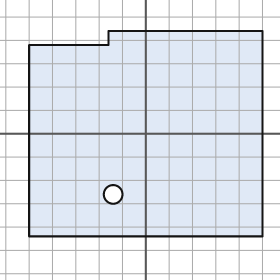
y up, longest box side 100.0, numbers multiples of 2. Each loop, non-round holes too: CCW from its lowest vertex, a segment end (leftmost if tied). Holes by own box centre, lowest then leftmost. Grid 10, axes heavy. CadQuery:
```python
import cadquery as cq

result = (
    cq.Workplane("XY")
    .moveTo(-50.0, -44.0)
    .lineTo(50.0, -44.0)
    .lineTo(50.0, 44.0)
    .lineTo(-16.0, 44.0)
    .lineTo(-16.0, 38.0)
    .lineTo(-50.0, 38.0)
    .close()
    .moveTo(-14.0, -26.0)
    .circle(4.0)
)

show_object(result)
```